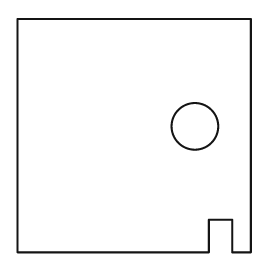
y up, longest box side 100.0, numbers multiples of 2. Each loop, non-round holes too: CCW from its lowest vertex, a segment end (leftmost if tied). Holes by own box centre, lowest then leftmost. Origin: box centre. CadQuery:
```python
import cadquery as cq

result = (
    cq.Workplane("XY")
    .moveTo(-50.0, -50.0)
    .lineTo(32.0, -50.0)
    .lineTo(32.0, -36.0)
    .lineTo(42.0, -36.0)
    .lineTo(42.0, -50.0)
    .lineTo(50.0, -50.0)
    .lineTo(50.0, 50.0)
    .lineTo(-50.0, 50.0)
    .close()
    .moveTo(26.0, 4.0)
    .circle(10.0)
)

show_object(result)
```